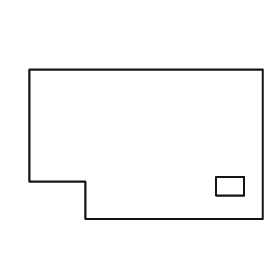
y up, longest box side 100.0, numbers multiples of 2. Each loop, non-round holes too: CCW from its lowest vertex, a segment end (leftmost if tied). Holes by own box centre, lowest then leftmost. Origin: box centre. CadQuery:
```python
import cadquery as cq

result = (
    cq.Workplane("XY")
    .moveTo(-26.0, -32.0)
    .lineTo(50.0, -32.0)
    .lineTo(50.0, 32.0)
    .lineTo(-50.0, 32.0)
    .lineTo(-50.0, -16.0)
    .lineTo(-26.0, -16.0)
    .close()
    .moveTo(30.0, -22.0)
    .lineTo(42.0, -22.0)
    .lineTo(42.0, -14.0)
    .lineTo(30.0, -14.0)
    .close()
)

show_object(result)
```